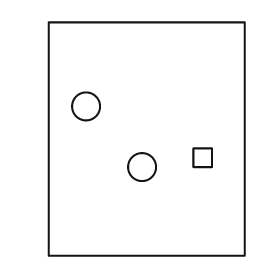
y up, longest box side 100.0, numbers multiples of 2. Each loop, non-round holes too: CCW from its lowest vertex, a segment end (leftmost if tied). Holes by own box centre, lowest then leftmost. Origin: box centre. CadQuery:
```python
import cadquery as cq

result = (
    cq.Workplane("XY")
    .moveTo(-42.0, -50.0)
    .lineTo(42.0, -50.0)
    .lineTo(42.0, 50.0)
    .lineTo(-42.0, 50.0)
    .close()
    .moveTo(-2.0, -12.0)
    .circle(6.0)
    .moveTo(20.0, -12.0)
    .lineTo(28.0, -12.0)
    .lineTo(28.0, -4.0)
    .lineTo(20.0, -4.0)
    .close()
    .moveTo(-26.0, 14.0)
    .circle(6.0)
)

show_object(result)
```